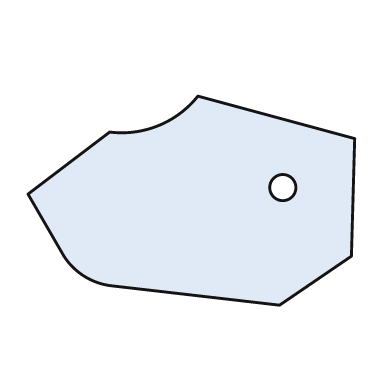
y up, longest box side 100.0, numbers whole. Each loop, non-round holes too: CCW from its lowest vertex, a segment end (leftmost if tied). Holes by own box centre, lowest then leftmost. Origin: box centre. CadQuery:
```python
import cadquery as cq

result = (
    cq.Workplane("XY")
    .moveTo(27.0, -32.0)
    .lineTo(49.0, -17.0)
    .lineTo(50.0, 19.0)
    .lineTo(2.0, 32.0)
    .threePointArc((-10.0, 23.0), (-25.0, 21.0))
    .lineTo(-50.0, 2.0)
    .lineTo(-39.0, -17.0)
    .threePointArc((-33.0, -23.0), (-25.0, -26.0))
    .close()
    .moveTo(28.0, 4.0)
    .circle(4.0)
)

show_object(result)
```